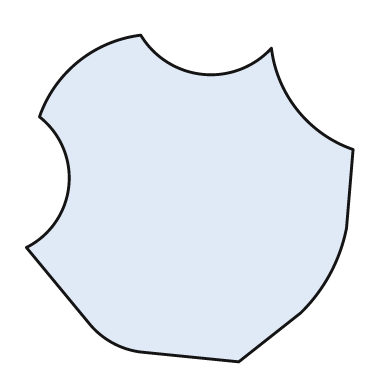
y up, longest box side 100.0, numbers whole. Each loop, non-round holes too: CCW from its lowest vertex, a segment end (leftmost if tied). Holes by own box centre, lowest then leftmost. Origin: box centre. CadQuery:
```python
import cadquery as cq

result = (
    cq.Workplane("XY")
    .moveTo(15.0, -50.0)
    .lineTo(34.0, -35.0)
    .threePointArc((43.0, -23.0), (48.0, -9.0))
    .lineTo(50.0, 15.0)
    .threePointArc((33.0, 27.0), (25.0, 46.0))
    .threePointArc((4.0, 38.0), (-15.0, 50.0))
    .threePointArc((-34.0, 42.0), (-46.0, 25.0))
    .threePointArc((-37.0, 4.0), (-50.0, -15.0))
    .lineTo(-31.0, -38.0)
    .threePointArc((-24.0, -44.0), (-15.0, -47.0))
    .close()
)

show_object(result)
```